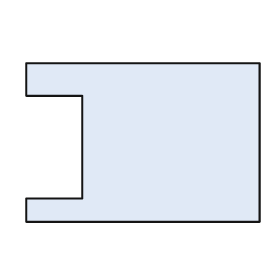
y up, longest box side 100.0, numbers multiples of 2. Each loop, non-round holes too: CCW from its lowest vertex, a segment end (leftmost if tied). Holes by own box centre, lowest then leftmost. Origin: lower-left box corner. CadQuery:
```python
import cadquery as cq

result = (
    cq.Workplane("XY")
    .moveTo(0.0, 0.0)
    .lineTo(100.0, 0.0)
    .lineTo(100.0, 68.0)
    .lineTo(0.0, 68.0)
    .lineTo(0.0, 54.0)
    .lineTo(24.0, 54.0)
    .lineTo(24.0, 10.0)
    .lineTo(0.0, 10.0)
    .close()
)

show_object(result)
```